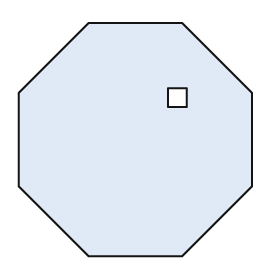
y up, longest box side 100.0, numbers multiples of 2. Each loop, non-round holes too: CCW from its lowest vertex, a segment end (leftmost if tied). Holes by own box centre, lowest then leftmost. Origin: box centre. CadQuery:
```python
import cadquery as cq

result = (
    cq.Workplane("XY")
    .moveTo(-20.0, -50.0)
    .lineTo(20.0, -50.0)
    .lineTo(50.0, -20.0)
    .lineTo(50.0, 20.0)
    .lineTo(20.0, 50.0)
    .lineTo(-20.0, 50.0)
    .lineTo(-50.0, 20.0)
    .lineTo(-50.0, -20.0)
    .close()
    .moveTo(14.0, 14.0)
    .lineTo(22.0, 14.0)
    .lineTo(22.0, 22.0)
    .lineTo(14.0, 22.0)
    .close()
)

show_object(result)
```